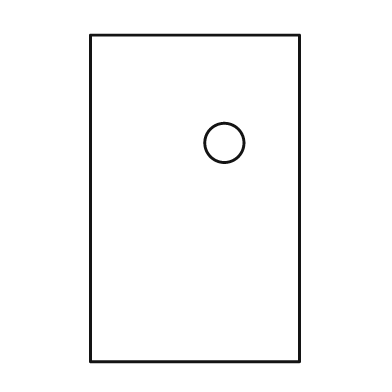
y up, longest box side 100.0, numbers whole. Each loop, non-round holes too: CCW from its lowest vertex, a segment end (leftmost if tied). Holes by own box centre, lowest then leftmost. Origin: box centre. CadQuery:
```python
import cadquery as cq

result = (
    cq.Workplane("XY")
    .moveTo(-32.0, -50.0)
    .lineTo(32.0, -50.0)
    .lineTo(32.0, 50.0)
    .lineTo(-32.0, 50.0)
    .close()
    .moveTo(9.0, 17.0)
    .circle(6.0)
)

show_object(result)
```